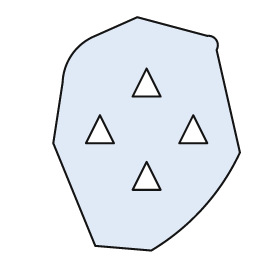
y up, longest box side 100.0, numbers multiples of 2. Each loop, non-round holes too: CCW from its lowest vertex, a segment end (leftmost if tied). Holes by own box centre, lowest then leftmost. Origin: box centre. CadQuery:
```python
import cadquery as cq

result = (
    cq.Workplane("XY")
    .moveTo(2.0, -50.0)
    .threePointArc((24.0, -32.0), (40.0, -8.0))
    .lineTo(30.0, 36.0)
    .threePointArc((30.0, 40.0), (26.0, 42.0))
    .lineTo(-4.0, 50.0)
    .lineTo(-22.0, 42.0)
    .threePointArc((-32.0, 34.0), (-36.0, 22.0))
    .lineTo(-40.0, -4.0)
    .lineTo(-22.0, -48.0)
    .close()
    .moveTo(-6.0, -24.0)
    .lineTo(6.0, -24.0)
    .lineTo(0.0, -12.0)
    .close()
    .moveTo(-26.0, -4.0)
    .lineTo(-14.0, -4.0)
    .lineTo(-20.0, 8.0)
    .close()
    .moveTo(14.0, -4.0)
    .lineTo(26.0, -4.0)
    .lineTo(20.0, 8.0)
    .close()
    .moveTo(-6.0, 16.0)
    .lineTo(6.0, 16.0)
    .lineTo(0.0, 28.0)
    .close()
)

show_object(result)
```